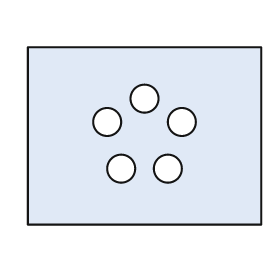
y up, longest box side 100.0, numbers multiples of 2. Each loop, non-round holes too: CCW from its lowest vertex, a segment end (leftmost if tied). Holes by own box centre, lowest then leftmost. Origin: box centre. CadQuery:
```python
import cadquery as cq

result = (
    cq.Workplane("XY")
    .moveTo(-50.0, -38.0)
    .lineTo(50.0, -38.0)
    .lineTo(50.0, 38.0)
    .lineTo(-50.0, 38.0)
    .close()
    .moveTo(-10.0, -14.0)
    .circle(6.0)
    .moveTo(10.0, -14.0)
    .circle(6.0)
    .moveTo(-16.0, 6.0)
    .circle(6.0)
    .moveTo(16.0, 6.0)
    .circle(6.0)
    .moveTo(0.0, 16.0)
    .circle(6.0)
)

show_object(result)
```